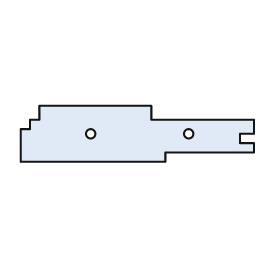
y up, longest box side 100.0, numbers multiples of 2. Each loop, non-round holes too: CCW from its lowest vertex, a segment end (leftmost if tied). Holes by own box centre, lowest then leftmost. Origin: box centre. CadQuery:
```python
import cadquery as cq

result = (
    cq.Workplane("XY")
    .moveTo(-50.0, -12.0)
    .lineTo(12.0, -12.0)
    .lineTo(12.0, -8.0)
    .lineTo(50.0, -8.0)
    .lineTo(50.0, -4.0)
    .lineTo(44.0, -4.0)
    .lineTo(44.0, 0.0)
    .lineTo(50.0, 0.0)
    .lineTo(50.0, 6.0)
    .lineTo(6.0, 6.0)
    .lineTo(6.0, 12.0)
    .lineTo(-42.0, 12.0)
    .lineTo(-42.0, 6.0)
    .lineTo(-46.0, 6.0)
    .lineTo(-46.0, 2.0)
    .lineTo(-50.0, 2.0)
    .close()
    .moveTo(-20.0, 0.0)
    .circle(2.0)
    .moveTo(22.0, 0.0)
    .circle(2.0)
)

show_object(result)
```